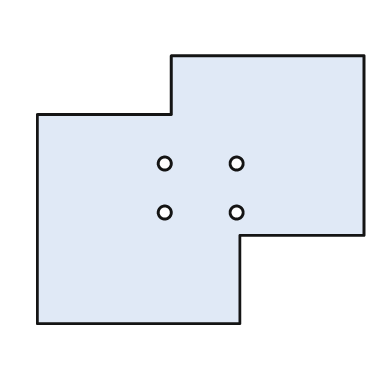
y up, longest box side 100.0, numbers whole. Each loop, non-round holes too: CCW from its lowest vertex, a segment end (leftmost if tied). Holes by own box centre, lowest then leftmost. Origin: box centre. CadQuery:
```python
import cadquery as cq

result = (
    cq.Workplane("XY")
    .moveTo(-50.0, -41.0)
    .lineTo(12.0, -41.0)
    .lineTo(12.0, -14.0)
    .lineTo(50.0, -14.0)
    .lineTo(50.0, 41.0)
    .lineTo(-9.0, 41.0)
    .lineTo(-9.0, 23.0)
    .lineTo(-50.0, 23.0)
    .close()
    .moveTo(-11.0, -7.0)
    .circle(2.0)
    .moveTo(11.0, -7.0)
    .circle(2.0)
    .moveTo(-11.0, 8.0)
    .circle(2.0)
    .moveTo(11.0, 8.0)
    .circle(2.0)
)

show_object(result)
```